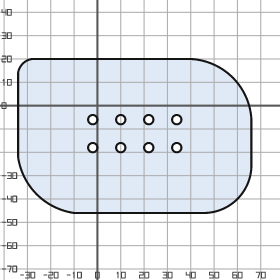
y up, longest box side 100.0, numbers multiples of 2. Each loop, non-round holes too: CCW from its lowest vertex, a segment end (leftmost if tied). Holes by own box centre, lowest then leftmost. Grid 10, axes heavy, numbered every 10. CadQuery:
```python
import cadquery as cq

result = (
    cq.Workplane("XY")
    .moveTo(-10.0, -46.0)
    .lineTo(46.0, -46.0)
    .threePointArc((60.0, -40.0), (66.0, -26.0))
    .lineTo(66.0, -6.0)
    .threePointArc((58.0, 12.0), (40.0, 20.0))
    .lineTo(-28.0, 20.0)
    .threePointArc((-32.0, 18.0), (-34.0, 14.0))
    .lineTo(-34.0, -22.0)
    .threePointArc((-26.0, -38.0), (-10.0, -46.0))
    .close()
    .moveTo(-2.0, -18.0)
    .circle(2.0)
    .moveTo(10.0, -18.0)
    .circle(2.0)
    .moveTo(22.0, -18.0)
    .circle(2.0)
    .moveTo(34.0, -18.0)
    .circle(2.0)
    .moveTo(-2.0, -6.0)
    .circle(2.0)
    .moveTo(10.0, -6.0)
    .circle(2.0)
    .moveTo(22.0, -6.0)
    .circle(2.0)
    .moveTo(34.0, -6.0)
    .circle(2.0)
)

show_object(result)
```